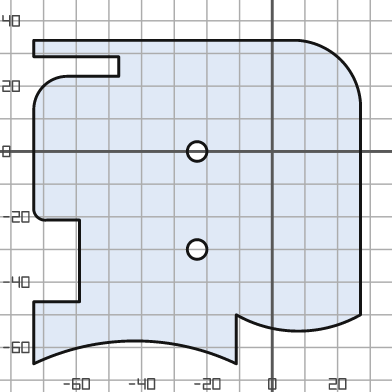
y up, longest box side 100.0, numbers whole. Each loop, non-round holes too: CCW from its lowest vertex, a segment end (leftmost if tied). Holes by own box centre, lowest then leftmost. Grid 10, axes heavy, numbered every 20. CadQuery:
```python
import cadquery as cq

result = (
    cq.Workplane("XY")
    .moveTo(-73.0, -65.0)
    .threePointArc((-42.0, -58.0), (-11.0, -65.0))
    .lineTo(-11.0, -50.0)
    .threePointArc((8.0, -55.0), (27.0, -50.0))
    .lineTo(27.0, 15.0)
    .threePointArc((21.0, 28.0), (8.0, 34.0))
    .lineTo(-73.0, 34.0)
    .lineTo(-73.0, 29.0)
    .lineTo(-47.0, 29.0)
    .lineTo(-47.0, 23.0)
    .lineTo(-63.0, 23.0)
    .threePointArc((-70.0, 20.0), (-73.0, 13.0))
    .lineTo(-73.0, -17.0)
    .threePointArc((-72.0, -20.0), (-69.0, -21.0))
    .lineTo(-59.0, -21.0)
    .lineTo(-59.0, -46.0)
    .lineTo(-73.0, -46.0)
    .close()
    .moveTo(-23.0, -30.0)
    .circle(3.0)
    .moveTo(-23.0, 0.0)
    .circle(3.0)
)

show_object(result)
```